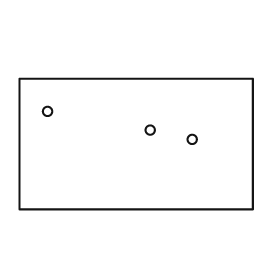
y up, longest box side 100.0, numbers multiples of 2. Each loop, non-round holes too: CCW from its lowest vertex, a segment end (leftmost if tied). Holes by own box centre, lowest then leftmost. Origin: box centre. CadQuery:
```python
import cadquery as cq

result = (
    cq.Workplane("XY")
    .moveTo(-50.0, -28.0)
    .lineTo(50.0, -28.0)
    .lineTo(50.0, 28.0)
    .lineTo(-50.0, 28.0)
    .close()
    .moveTo(24.0, 2.0)
    .circle(2.0)
    .moveTo(6.0, 6.0)
    .circle(2.0)
    .moveTo(-38.0, 14.0)
    .circle(2.0)
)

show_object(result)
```